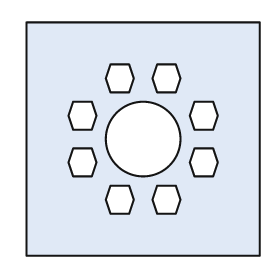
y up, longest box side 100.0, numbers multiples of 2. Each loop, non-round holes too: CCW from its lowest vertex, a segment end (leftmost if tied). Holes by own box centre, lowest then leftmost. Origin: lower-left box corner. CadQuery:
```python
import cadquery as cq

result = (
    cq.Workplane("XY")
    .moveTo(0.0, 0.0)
    .lineTo(100.0, 0.0)
    .lineTo(100.0, 100.0)
    .lineTo(0.0, 100.0)
    .close()
    .moveTo(36.0, 18.0)
    .lineTo(44.0, 18.0)
    .lineTo(46.0, 24.0)
    .lineTo(44.0, 30.0)
    .lineTo(36.0, 30.0)
    .lineTo(34.0, 24.0)
    .close()
    .moveTo(56.0, 18.0)
    .lineTo(64.0, 18.0)
    .lineTo(66.0, 24.0)
    .lineTo(64.0, 30.0)
    .lineTo(56.0, 30.0)
    .lineTo(54.0, 24.0)
    .close()
    .moveTo(20.0, 34.0)
    .lineTo(28.0, 34.0)
    .lineTo(30.0, 40.0)
    .lineTo(28.0, 46.0)
    .lineTo(20.0, 46.0)
    .lineTo(18.0, 40.0)
    .close()
    .moveTo(72.0, 34.0)
    .lineTo(80.0, 34.0)
    .lineTo(82.0, 40.0)
    .lineTo(80.0, 46.0)
    .lineTo(72.0, 46.0)
    .lineTo(70.0, 40.0)
    .close()
    .moveTo(50.0, 50.0)
    .circle(16.0)
    .moveTo(20.0, 54.0)
    .lineTo(28.0, 54.0)
    .lineTo(30.0, 60.0)
    .lineTo(28.0, 66.0)
    .lineTo(20.0, 66.0)
    .lineTo(18.0, 60.0)
    .close()
    .moveTo(72.0, 54.0)
    .lineTo(80.0, 54.0)
    .lineTo(82.0, 60.0)
    .lineTo(80.0, 66.0)
    .lineTo(72.0, 66.0)
    .lineTo(70.0, 60.0)
    .close()
    .moveTo(36.0, 70.0)
    .lineTo(44.0, 70.0)
    .lineTo(46.0, 76.0)
    .lineTo(44.0, 82.0)
    .lineTo(36.0, 82.0)
    .lineTo(34.0, 76.0)
    .close()
    .moveTo(56.0, 70.0)
    .lineTo(64.0, 70.0)
    .lineTo(66.0, 76.0)
    .lineTo(64.0, 82.0)
    .lineTo(56.0, 82.0)
    .lineTo(54.0, 76.0)
    .close()
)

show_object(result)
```